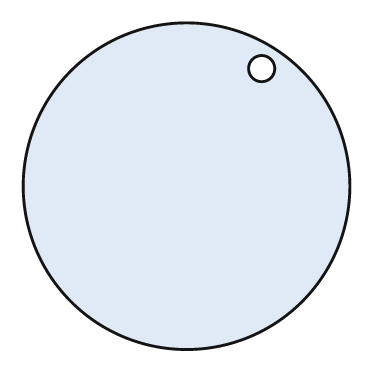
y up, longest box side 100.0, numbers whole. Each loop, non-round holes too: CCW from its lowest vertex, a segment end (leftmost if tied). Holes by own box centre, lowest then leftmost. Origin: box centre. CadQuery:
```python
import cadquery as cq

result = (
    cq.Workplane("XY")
    .moveTo(0.0, 0.0)
    .circle(50.0)
    .moveTo(23.0, 36.0)
    .circle(4.0)
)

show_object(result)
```